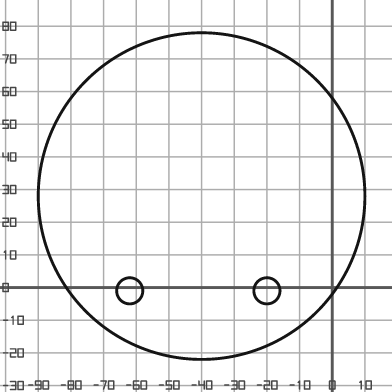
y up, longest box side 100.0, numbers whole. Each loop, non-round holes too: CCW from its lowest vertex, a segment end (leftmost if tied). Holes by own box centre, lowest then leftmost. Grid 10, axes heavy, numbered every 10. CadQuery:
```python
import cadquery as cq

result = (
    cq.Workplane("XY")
    .moveTo(-40.0, 28.0)
    .circle(50.0)
    .moveTo(-62.0, -1.0)
    .circle(4.0)
    .moveTo(-20.0, -1.0)
    .circle(4.0)
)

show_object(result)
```